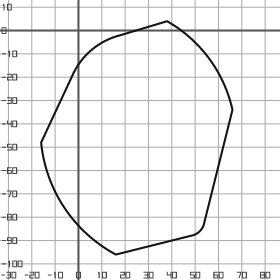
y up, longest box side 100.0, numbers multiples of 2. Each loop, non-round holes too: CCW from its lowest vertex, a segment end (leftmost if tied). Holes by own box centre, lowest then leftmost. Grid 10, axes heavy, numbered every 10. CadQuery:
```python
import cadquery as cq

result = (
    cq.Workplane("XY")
    .moveTo(16.0, -96.0)
    .lineTo(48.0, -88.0)
    .threePointArc((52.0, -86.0), (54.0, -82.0))
    .lineTo(66.0, -34.0)
    .threePointArc((56.0, -12.0), (38.0, 4.0))
    .lineTo(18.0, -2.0)
    .threePointArc((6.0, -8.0), (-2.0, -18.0))
    .lineTo(-16.0, -48.0)
    .threePointArc((-6.0, -76.0), (16.0, -96.0))
    .close()
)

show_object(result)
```